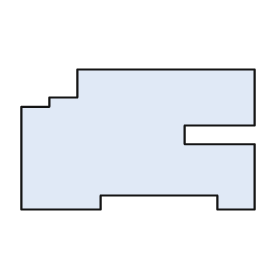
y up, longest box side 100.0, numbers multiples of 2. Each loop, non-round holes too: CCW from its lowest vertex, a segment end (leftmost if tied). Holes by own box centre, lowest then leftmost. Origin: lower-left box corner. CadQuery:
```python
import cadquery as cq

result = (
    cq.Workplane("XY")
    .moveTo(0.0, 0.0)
    .lineTo(34.0, 0.0)
    .lineTo(34.0, 6.0)
    .lineTo(84.0, 6.0)
    .lineTo(84.0, 0.0)
    .lineTo(100.0, 0.0)
    .lineTo(100.0, 28.0)
    .lineTo(70.0, 28.0)
    .lineTo(70.0, 36.0)
    .lineTo(100.0, 36.0)
    .lineTo(100.0, 60.0)
    .lineTo(24.0, 60.0)
    .lineTo(24.0, 48.0)
    .lineTo(12.0, 48.0)
    .lineTo(12.0, 44.0)
    .lineTo(0.0, 44.0)
    .close()
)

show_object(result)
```